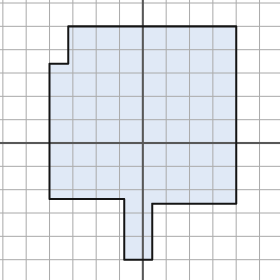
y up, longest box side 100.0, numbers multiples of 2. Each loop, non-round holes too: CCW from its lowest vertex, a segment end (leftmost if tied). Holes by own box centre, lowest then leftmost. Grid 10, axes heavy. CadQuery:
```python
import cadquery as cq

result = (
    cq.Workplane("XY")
    .moveTo(-8.0, -50.0)
    .lineTo(4.0, -50.0)
    .lineTo(4.0, -26.0)
    .lineTo(40.0, -26.0)
    .lineTo(40.0, 50.0)
    .lineTo(-32.0, 50.0)
    .lineTo(-32.0, 34.0)
    .lineTo(-40.0, 34.0)
    .lineTo(-40.0, -24.0)
    .lineTo(-8.0, -24.0)
    .close()
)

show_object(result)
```